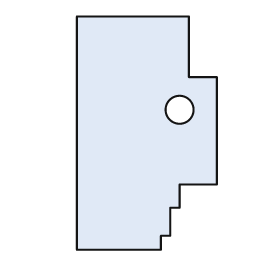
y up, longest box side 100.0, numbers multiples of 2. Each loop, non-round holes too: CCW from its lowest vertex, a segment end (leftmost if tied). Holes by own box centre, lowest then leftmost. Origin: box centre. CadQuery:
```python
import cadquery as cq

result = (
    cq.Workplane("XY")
    .moveTo(-30.0, -50.0)
    .lineTo(6.0, -50.0)
    .lineTo(6.0, -44.0)
    .lineTo(10.0, -44.0)
    .lineTo(10.0, -32.0)
    .lineTo(14.0, -32.0)
    .lineTo(14.0, -22.0)
    .lineTo(30.0, -22.0)
    .lineTo(30.0, 24.0)
    .lineTo(18.0, 24.0)
    .lineTo(18.0, 50.0)
    .lineTo(-30.0, 50.0)
    .close()
    .moveTo(14.0, 10.0)
    .circle(6.0)
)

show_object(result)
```